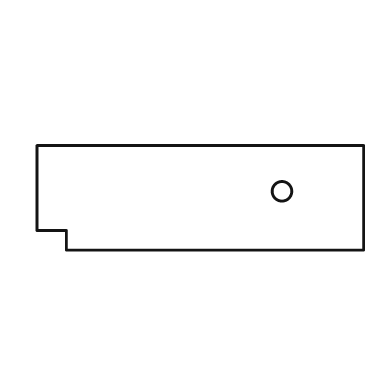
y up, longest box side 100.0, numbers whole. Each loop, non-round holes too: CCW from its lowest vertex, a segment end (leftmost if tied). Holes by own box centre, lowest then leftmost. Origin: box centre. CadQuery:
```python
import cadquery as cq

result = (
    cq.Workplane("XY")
    .moveTo(-41.0, -16.0)
    .lineTo(50.0, -16.0)
    .lineTo(50.0, 16.0)
    .lineTo(-50.0, 16.0)
    .lineTo(-50.0, -10.0)
    .lineTo(-41.0, -10.0)
    .close()
    .moveTo(25.0, 2.0)
    .circle(3.0)
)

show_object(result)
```